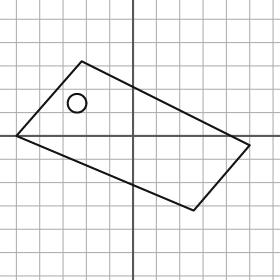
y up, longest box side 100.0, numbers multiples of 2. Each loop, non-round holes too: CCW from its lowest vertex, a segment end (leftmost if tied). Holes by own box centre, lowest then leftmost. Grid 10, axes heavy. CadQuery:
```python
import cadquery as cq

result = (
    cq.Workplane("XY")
    .moveTo(26.0, -32.0)
    .lineTo(50.0, -4.0)
    .lineTo(-22.0, 32.0)
    .lineTo(-50.0, 0.0)
    .close()
    .moveTo(-24.0, 14.0)
    .circle(4.0)
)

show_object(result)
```